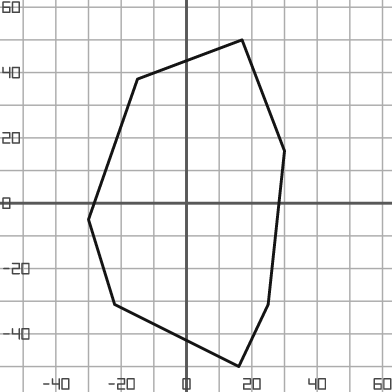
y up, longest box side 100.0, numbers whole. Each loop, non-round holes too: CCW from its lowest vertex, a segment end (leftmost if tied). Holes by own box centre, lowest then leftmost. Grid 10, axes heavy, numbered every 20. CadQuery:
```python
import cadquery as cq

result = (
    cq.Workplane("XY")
    .moveTo(16.0, -50.0)
    .lineTo(25.0, -31.0)
    .lineTo(30.0, 16.0)
    .lineTo(17.0, 50.0)
    .lineTo(-15.0, 38.0)
    .lineTo(-30.0, -5.0)
    .lineTo(-22.0, -31.0)
    .close()
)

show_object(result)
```